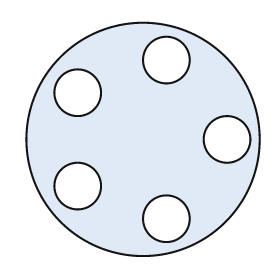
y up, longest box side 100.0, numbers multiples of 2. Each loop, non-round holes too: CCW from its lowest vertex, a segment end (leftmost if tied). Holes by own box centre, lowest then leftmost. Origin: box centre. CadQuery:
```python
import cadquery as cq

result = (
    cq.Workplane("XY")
    .moveTo(0.0, 0.0)
    .circle(50.0)
    .moveTo(10.0, -34.0)
    .circle(10.0)
    .moveTo(-28.0, -20.0)
    .circle(10.0)
    .moveTo(36.0, 0.0)
    .circle(10.0)
    .moveTo(-28.0, 20.0)
    .circle(10.0)
    .moveTo(10.0, 34.0)
    .circle(10.0)
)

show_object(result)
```